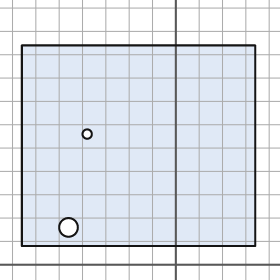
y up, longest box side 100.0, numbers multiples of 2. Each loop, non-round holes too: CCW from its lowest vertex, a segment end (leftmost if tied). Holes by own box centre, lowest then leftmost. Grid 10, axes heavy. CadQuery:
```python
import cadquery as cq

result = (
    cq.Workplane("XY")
    .moveTo(-66.0, 8.0)
    .lineTo(34.0, 8.0)
    .lineTo(34.0, 94.0)
    .lineTo(-66.0, 94.0)
    .close()
    .moveTo(-46.0, 16.0)
    .circle(4.0)
    .moveTo(-38.0, 56.0)
    .circle(2.0)
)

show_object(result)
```